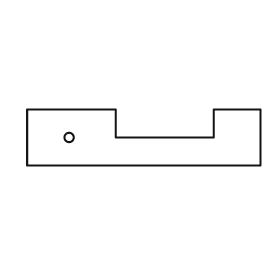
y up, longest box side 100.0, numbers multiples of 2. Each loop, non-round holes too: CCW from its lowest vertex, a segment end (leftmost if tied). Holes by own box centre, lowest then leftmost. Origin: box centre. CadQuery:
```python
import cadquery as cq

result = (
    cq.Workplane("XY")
    .moveTo(-50.0, -12.0)
    .lineTo(50.0, -12.0)
    .lineTo(50.0, 12.0)
    .lineTo(30.0, 12.0)
    .lineTo(30.0, 0.0)
    .lineTo(-12.0, 0.0)
    .lineTo(-12.0, 12.0)
    .lineTo(-50.0, 12.0)
    .close()
    .moveTo(-32.0, 0.0)
    .circle(2.0)
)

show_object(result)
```